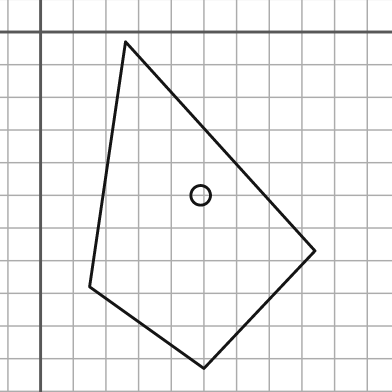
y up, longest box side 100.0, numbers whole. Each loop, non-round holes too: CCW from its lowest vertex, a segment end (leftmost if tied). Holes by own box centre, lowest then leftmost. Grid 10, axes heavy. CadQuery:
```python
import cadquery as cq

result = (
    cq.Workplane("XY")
    .moveTo(50.0, -103.0)
    .lineTo(84.0, -67.0)
    .lineTo(26.0, -3.0)
    .lineTo(15.0, -78.0)
    .close()
    .moveTo(49.0, -50.0)
    .circle(3.0)
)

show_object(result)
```